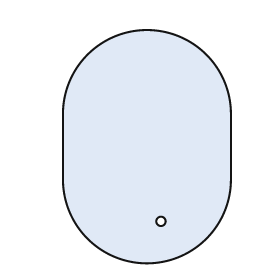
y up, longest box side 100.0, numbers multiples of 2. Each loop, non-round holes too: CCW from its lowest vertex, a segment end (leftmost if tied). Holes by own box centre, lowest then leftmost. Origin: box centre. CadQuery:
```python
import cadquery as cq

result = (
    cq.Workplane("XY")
    .moveTo(-36.0, -14.0)
    .threePointArc((0.0, -50.0), (36.0, -14.0))
    .lineTo(36.0, 14.0)
    .threePointArc((0.0, 50.0), (-36.0, 14.0))
    .close()
    .moveTo(6.0, -32.0)
    .circle(2.0)
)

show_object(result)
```